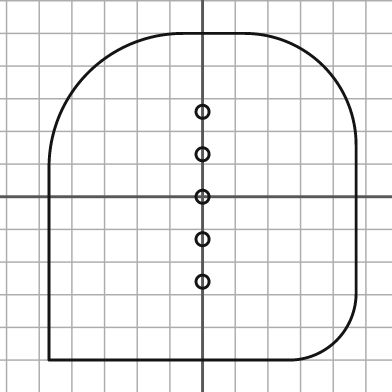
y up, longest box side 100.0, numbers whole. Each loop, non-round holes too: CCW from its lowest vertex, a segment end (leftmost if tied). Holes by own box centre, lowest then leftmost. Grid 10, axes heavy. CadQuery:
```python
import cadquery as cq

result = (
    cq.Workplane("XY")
    .moveTo(-47.0, -50.0)
    .lineTo(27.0, -50.0)
    .threePointArc((41.0, -44.0), (47.0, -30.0))
    .lineTo(47.0, 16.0)
    .threePointArc((37.0, 40.0), (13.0, 50.0))
    .lineTo(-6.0, 50.0)
    .threePointArc((-35.0, 38.0), (-47.0, 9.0))
    .close()
    .moveTo(0.0, -26.0)
    .circle(2.0)
    .moveTo(0.0, -13.0)
    .circle(2.0)
    .moveTo(0.0, 0.0)
    .circle(2.0)
    .moveTo(0.0, 13.0)
    .circle(2.0)
    .moveTo(0.0, 26.0)
    .circle(2.0)
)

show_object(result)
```